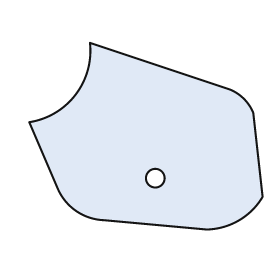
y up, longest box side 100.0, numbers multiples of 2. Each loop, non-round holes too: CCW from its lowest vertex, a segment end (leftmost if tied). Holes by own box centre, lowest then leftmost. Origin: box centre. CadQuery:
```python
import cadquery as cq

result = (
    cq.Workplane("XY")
    .moveTo(26.0, -40.0)
    .threePointArc((40.0, -36.0), (50.0, -26.0))
    .lineTo(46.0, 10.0)
    .threePointArc((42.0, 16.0), (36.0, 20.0))
    .lineTo(-24.0, 40.0)
    .threePointArc((-30.0, 18.0), (-50.0, 6.0))
    .lineTo(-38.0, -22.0)
    .threePointArc((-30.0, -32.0), (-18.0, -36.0))
    .close()
    .moveTo(4.0, -18.0)
    .circle(4.0)
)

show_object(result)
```